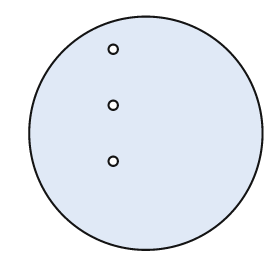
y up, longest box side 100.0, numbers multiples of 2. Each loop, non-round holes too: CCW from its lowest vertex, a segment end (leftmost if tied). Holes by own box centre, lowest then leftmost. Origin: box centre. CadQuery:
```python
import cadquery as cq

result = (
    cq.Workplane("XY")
    .moveTo(0.0, 0.0)
    .circle(50.0)
    .moveTo(-14.0, -12.0)
    .circle(2.0)
    .moveTo(-14.0, 12.0)
    .circle(2.0)
    .moveTo(-14.0, 36.0)
    .circle(2.0)
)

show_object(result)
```